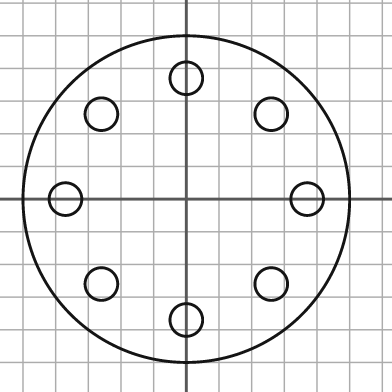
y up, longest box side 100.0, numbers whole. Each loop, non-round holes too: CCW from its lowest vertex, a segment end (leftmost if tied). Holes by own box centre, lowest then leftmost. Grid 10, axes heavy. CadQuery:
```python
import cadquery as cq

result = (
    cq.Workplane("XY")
    .moveTo(0.0, 0.0)
    .circle(50.0)
    .moveTo(0.0, -37.0)
    .circle(5.0)
    .moveTo(-26.0, -26.0)
    .circle(5.0)
    .moveTo(26.0, -26.0)
    .circle(5.0)
    .moveTo(-37.0, 0.0)
    .circle(5.0)
    .moveTo(37.0, 0.0)
    .circle(5.0)
    .moveTo(-26.0, 26.0)
    .circle(5.0)
    .moveTo(26.0, 26.0)
    .circle(5.0)
    .moveTo(0.0, 37.0)
    .circle(5.0)
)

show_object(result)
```